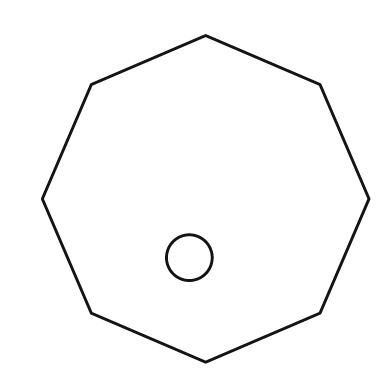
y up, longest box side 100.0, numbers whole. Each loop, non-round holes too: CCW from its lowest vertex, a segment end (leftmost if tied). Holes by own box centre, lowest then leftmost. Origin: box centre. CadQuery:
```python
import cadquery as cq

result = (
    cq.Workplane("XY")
    .moveTo(0.0, -50.0)
    .lineTo(35.0, -35.0)
    .lineTo(50.0, 0.0)
    .lineTo(35.0, 35.0)
    .lineTo(0.0, 50.0)
    .lineTo(-35.0, 35.0)
    .lineTo(-50.0, 0.0)
    .lineTo(-35.0, -35.0)
    .close()
    .moveTo(-5.0, -18.0)
    .circle(7.0)
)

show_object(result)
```